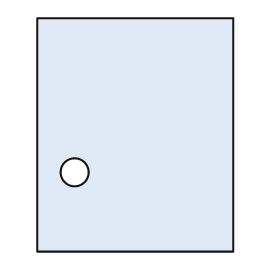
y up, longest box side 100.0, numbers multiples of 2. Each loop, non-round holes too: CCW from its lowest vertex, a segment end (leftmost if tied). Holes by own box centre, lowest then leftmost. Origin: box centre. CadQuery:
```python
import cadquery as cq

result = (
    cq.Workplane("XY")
    .moveTo(-42.0, -50.0)
    .lineTo(42.0, -50.0)
    .lineTo(42.0, 50.0)
    .lineTo(-42.0, 50.0)
    .close()
    .moveTo(-26.0, -16.0)
    .circle(6.0)
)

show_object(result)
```